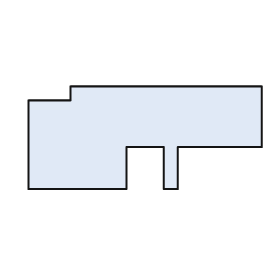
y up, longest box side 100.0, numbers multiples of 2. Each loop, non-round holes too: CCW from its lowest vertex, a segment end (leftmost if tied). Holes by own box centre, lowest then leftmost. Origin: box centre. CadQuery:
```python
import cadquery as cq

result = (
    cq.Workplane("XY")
    .moveTo(-50.0, -22.0)
    .lineTo(-8.0, -22.0)
    .lineTo(-8.0, -4.0)
    .lineTo(8.0, -4.0)
    .lineTo(8.0, -22.0)
    .lineTo(14.0, -22.0)
    .lineTo(14.0, -4.0)
    .lineTo(50.0, -4.0)
    .lineTo(50.0, 22.0)
    .lineTo(-32.0, 22.0)
    .lineTo(-32.0, 16.0)
    .lineTo(-50.0, 16.0)
    .close()
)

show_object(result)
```